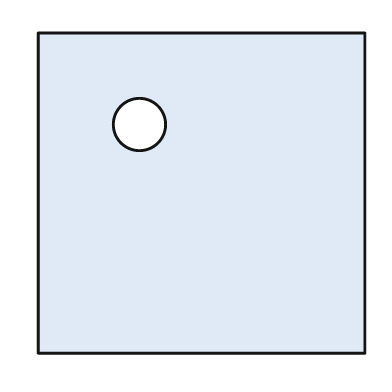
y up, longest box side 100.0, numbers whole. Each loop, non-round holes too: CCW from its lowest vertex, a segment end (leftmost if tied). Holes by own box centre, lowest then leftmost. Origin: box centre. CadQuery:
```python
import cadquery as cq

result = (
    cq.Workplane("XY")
    .moveTo(-50.0, -49.0)
    .lineTo(50.0, -49.0)
    .lineTo(50.0, 49.0)
    .lineTo(-50.0, 49.0)
    .close()
    .moveTo(-19.0, 21.0)
    .circle(8.0)
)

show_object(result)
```